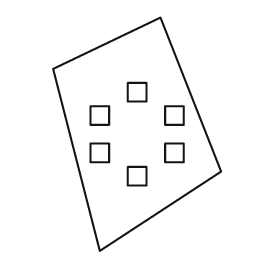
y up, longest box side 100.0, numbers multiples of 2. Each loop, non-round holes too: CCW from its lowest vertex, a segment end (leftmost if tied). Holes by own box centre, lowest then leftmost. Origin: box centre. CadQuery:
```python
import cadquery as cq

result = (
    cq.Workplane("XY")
    .moveTo(-16.0, -50.0)
    .lineTo(36.0, -16.0)
    .lineTo(10.0, 50.0)
    .lineTo(-36.0, 28.0)
    .close()
    .moveTo(-4.0, -22.0)
    .lineTo(4.0, -22.0)
    .lineTo(4.0, -14.0)
    .lineTo(-4.0, -14.0)
    .close()
    .moveTo(-20.0, -12.0)
    .lineTo(-12.0, -12.0)
    .lineTo(-12.0, -4.0)
    .lineTo(-20.0, -4.0)
    .close()
    .moveTo(12.0, -12.0)
    .lineTo(20.0, -12.0)
    .lineTo(20.0, -4.0)
    .lineTo(12.0, -4.0)
    .close()
    .moveTo(-20.0, 4.0)
    .lineTo(-12.0, 4.0)
    .lineTo(-12.0, 12.0)
    .lineTo(-20.0, 12.0)
    .close()
    .moveTo(12.0, 4.0)
    .lineTo(20.0, 4.0)
    .lineTo(20.0, 12.0)
    .lineTo(12.0, 12.0)
    .close()
    .moveTo(-4.0, 14.0)
    .lineTo(4.0, 14.0)
    .lineTo(4.0, 22.0)
    .lineTo(-4.0, 22.0)
    .close()
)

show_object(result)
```